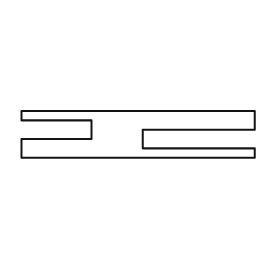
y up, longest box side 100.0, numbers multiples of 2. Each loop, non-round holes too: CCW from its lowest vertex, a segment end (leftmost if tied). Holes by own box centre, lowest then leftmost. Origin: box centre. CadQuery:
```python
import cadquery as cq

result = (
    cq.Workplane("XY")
    .moveTo(-50.0, -10.0)
    .lineTo(50.0, -10.0)
    .lineTo(50.0, -6.0)
    .lineTo(2.0, -6.0)
    .lineTo(2.0, 2.0)
    .lineTo(50.0, 2.0)
    .lineTo(50.0, 10.0)
    .lineTo(-50.0, 10.0)
    .lineTo(-50.0, 6.0)
    .lineTo(-20.0, 6.0)
    .lineTo(-20.0, -2.0)
    .lineTo(-50.0, -2.0)
    .close()
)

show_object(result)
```